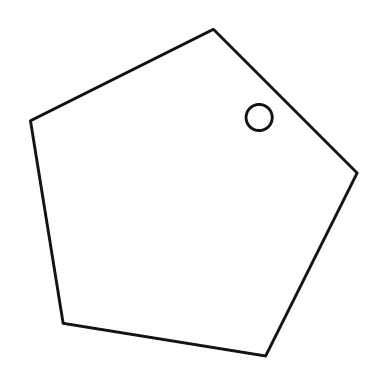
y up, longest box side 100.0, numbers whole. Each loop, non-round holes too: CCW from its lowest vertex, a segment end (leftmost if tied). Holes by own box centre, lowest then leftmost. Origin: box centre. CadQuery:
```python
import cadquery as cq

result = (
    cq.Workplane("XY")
    .moveTo(22.0, -50.0)
    .lineTo(50.0, 6.0)
    .lineTo(6.0, 50.0)
    .lineTo(-50.0, 22.0)
    .lineTo(-40.0, -40.0)
    .close()
    .moveTo(20.0, 23.0)
    .circle(4.0)
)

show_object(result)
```